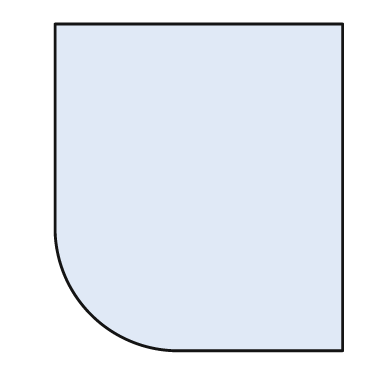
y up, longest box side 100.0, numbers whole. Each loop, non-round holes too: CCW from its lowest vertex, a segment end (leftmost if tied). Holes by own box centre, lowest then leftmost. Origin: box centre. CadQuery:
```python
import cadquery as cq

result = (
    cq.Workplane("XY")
    .moveTo(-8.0, -50.0)
    .lineTo(44.0, -50.0)
    .lineTo(44.0, 50.0)
    .lineTo(-44.0, 50.0)
    .lineTo(-44.0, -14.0)
    .threePointArc((-33.0, -39.0), (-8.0, -50.0))
    .close()
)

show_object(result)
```